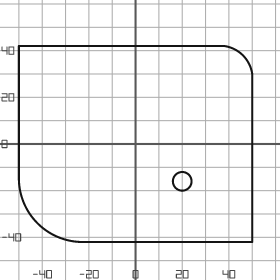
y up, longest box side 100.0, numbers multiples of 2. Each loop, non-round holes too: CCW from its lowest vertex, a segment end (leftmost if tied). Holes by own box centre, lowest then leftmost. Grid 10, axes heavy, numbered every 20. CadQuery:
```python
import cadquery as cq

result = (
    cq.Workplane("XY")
    .moveTo(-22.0, -42.0)
    .lineTo(50.0, -42.0)
    .lineTo(50.0, 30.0)
    .threePointArc((46.0, 38.0), (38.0, 42.0))
    .lineTo(-50.0, 42.0)
    .lineTo(-50.0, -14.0)
    .threePointArc((-42.0, -34.0), (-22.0, -42.0))
    .close()
    .moveTo(20.0, -16.0)
    .circle(4.0)
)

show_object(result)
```